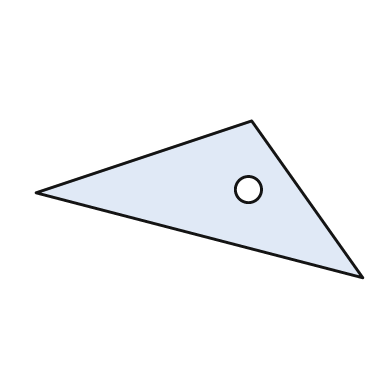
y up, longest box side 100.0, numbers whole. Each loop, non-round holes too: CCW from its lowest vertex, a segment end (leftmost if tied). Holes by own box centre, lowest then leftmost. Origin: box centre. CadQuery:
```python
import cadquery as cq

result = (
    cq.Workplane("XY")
    .moveTo(50.0, -24.0)
    .lineTo(16.0, 24.0)
    .lineTo(-50.0, 2.0)
    .close()
    .moveTo(15.0, 3.0)
    .circle(4.0)
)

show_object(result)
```